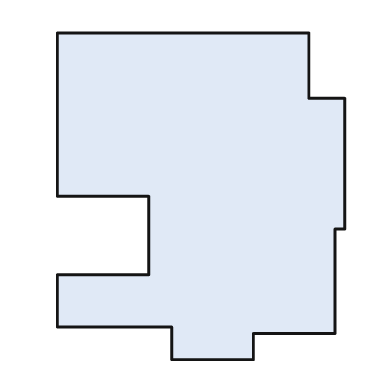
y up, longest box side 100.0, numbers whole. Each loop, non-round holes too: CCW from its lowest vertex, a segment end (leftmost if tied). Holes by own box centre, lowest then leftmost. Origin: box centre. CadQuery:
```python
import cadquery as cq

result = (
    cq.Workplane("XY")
    .moveTo(-9.0, -50.0)
    .lineTo(16.0, -50.0)
    .lineTo(16.0, -42.0)
    .lineTo(41.0, -42.0)
    .lineTo(41.0, -10.0)
    .lineTo(44.0, -10.0)
    .lineTo(44.0, 30.0)
    .lineTo(33.0, 30.0)
    .lineTo(33.0, 50.0)
    .lineTo(-44.0, 50.0)
    .lineTo(-44.0, 0.0)
    .lineTo(-16.0, 0.0)
    .lineTo(-16.0, -24.0)
    .lineTo(-44.0, -24.0)
    .lineTo(-44.0, -40.0)
    .lineTo(-9.0, -40.0)
    .close()
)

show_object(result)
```